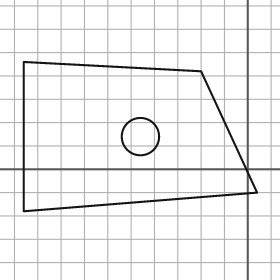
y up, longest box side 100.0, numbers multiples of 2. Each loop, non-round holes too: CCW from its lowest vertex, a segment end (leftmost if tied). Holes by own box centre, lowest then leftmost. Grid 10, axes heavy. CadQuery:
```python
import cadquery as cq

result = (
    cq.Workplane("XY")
    .moveTo(-96.0, -18.0)
    .lineTo(4.0, -10.0)
    .lineTo(-20.0, 42.0)
    .lineTo(-96.0, 46.0)
    .close()
    .moveTo(-46.0, 14.0)
    .circle(8.0)
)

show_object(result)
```